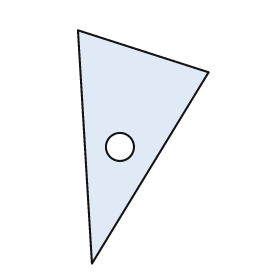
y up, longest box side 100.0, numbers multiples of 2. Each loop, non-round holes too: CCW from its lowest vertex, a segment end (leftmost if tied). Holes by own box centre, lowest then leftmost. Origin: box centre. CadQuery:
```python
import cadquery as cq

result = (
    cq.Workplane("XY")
    .moveTo(-22.0, -50.0)
    .lineTo(28.0, 32.0)
    .lineTo(-28.0, 50.0)
    .close()
    .moveTo(-10.0, 0.0)
    .circle(6.0)
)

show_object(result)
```